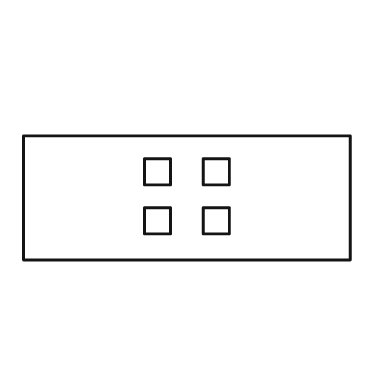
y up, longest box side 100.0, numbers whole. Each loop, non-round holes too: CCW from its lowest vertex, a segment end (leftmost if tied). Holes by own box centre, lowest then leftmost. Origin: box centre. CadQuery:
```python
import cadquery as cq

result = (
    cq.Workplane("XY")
    .moveTo(-50.0, -19.0)
    .lineTo(50.0, -19.0)
    .lineTo(50.0, 19.0)
    .lineTo(-50.0, 19.0)
    .close()
    .moveTo(-13.0, -11.0)
    .lineTo(-5.0, -11.0)
    .lineTo(-5.0, -3.0)
    .lineTo(-13.0, -3.0)
    .close()
    .moveTo(5.0, -11.0)
    .lineTo(13.0, -11.0)
    .lineTo(13.0, -3.0)
    .lineTo(5.0, -3.0)
    .close()
    .moveTo(-13.0, 4.0)
    .lineTo(-5.0, 4.0)
    .lineTo(-5.0, 12.0)
    .lineTo(-13.0, 12.0)
    .close()
    .moveTo(5.0, 4.0)
    .lineTo(13.0, 4.0)
    .lineTo(13.0, 12.0)
    .lineTo(5.0, 12.0)
    .close()
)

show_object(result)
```